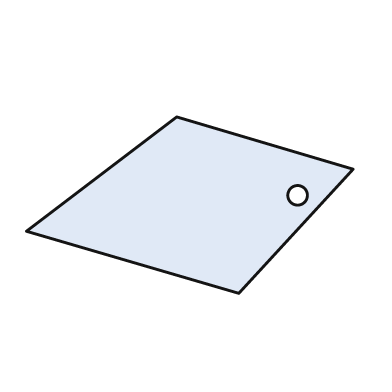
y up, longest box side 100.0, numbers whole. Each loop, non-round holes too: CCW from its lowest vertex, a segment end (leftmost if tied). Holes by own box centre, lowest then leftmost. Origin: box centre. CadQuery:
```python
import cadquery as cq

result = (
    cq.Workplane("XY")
    .moveTo(15.0, -27.0)
    .lineTo(50.0, 11.0)
    .lineTo(-4.0, 27.0)
    .lineTo(-50.0, -8.0)
    .close()
    .moveTo(33.0, 3.0)
    .circle(3.0)
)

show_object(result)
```